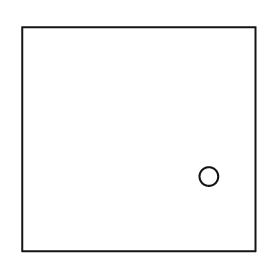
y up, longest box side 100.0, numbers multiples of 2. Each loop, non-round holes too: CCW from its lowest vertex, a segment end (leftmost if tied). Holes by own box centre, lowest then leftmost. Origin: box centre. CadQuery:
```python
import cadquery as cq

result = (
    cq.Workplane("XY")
    .moveTo(-50.0, -48.0)
    .lineTo(50.0, -48.0)
    .lineTo(50.0, 48.0)
    .lineTo(-50.0, 48.0)
    .close()
    .moveTo(30.0, -16.0)
    .circle(4.0)
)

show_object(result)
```